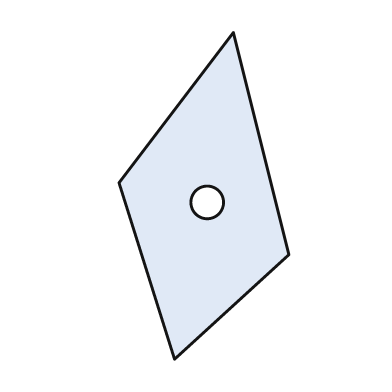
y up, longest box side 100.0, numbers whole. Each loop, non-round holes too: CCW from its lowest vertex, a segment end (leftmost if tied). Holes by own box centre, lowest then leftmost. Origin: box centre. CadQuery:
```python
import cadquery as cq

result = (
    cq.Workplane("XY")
    .moveTo(-9.0, -50.0)
    .lineTo(26.0, -18.0)
    .lineTo(9.0, 50.0)
    .lineTo(-26.0, 4.0)
    .close()
    .moveTo(1.0, -2.0)
    .circle(5.0)
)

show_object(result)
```